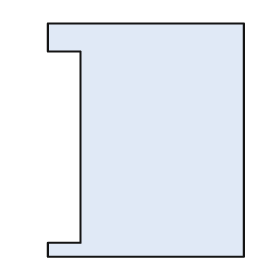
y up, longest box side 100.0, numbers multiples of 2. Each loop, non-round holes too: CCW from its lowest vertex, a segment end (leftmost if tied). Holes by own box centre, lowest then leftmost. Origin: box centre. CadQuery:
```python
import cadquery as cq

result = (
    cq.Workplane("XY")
    .moveTo(-42.0, -50.0)
    .lineTo(42.0, -50.0)
    .lineTo(42.0, 50.0)
    .lineTo(-42.0, 50.0)
    .lineTo(-42.0, 38.0)
    .lineTo(-28.0, 38.0)
    .lineTo(-28.0, -44.0)
    .lineTo(-42.0, -44.0)
    .close()
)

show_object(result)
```